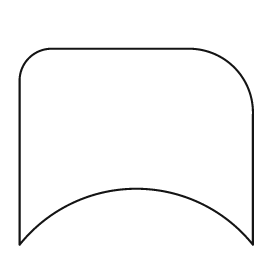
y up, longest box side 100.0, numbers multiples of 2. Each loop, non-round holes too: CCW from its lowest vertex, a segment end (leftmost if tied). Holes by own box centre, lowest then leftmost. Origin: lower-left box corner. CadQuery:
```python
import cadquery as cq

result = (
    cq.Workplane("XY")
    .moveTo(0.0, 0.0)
    .threePointArc((50.0, 24.0), (100.0, 0.0))
    .lineTo(100.0, 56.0)
    .threePointArc((92.0, 76.0), (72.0, 84.0))
    .lineTo(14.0, 84.0)
    .threePointArc((4.0, 80.0), (0.0, 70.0))
    .close()
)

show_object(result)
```